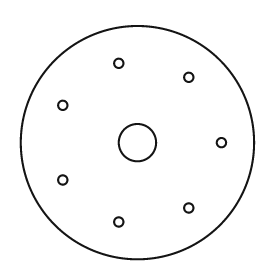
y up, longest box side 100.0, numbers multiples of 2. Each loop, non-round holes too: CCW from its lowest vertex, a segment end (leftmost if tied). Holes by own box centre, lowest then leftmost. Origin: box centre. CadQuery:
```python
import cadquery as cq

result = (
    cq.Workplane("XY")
    .moveTo(0.0, 0.0)
    .circle(50.0)
    .moveTo(-8.0, -34.0)
    .circle(2.0)
    .moveTo(22.0, -28.0)
    .circle(2.0)
    .moveTo(-32.0, -16.0)
    .circle(2.0)
    .moveTo(0.0, 0.0)
    .circle(8.0)
    .moveTo(36.0, 0.0)
    .circle(2.0)
    .moveTo(-32.0, 16.0)
    .circle(2.0)
    .moveTo(22.0, 28.0)
    .circle(2.0)
    .moveTo(-8.0, 34.0)
    .circle(2.0)
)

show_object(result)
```